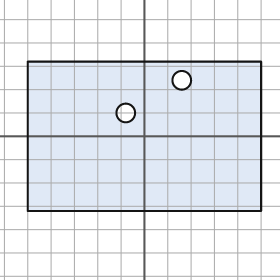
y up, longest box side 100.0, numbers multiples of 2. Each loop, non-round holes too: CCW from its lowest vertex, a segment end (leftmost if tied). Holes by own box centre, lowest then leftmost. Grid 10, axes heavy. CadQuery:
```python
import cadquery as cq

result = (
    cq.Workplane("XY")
    .moveTo(-50.0, -32.0)
    .lineTo(50.0, -32.0)
    .lineTo(50.0, 32.0)
    .lineTo(-50.0, 32.0)
    .close()
    .moveTo(-8.0, 10.0)
    .circle(4.0)
    .moveTo(16.0, 24.0)
    .circle(4.0)
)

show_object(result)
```